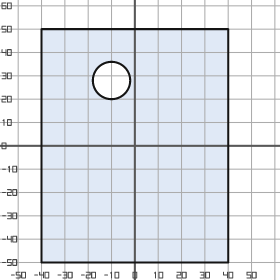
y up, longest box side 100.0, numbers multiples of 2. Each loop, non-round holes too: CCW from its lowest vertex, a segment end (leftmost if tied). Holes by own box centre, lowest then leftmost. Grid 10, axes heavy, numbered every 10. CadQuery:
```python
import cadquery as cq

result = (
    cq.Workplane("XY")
    .moveTo(-40.0, -50.0)
    .lineTo(40.0, -50.0)
    .lineTo(40.0, 50.0)
    .lineTo(-40.0, 50.0)
    .close()
    .moveTo(-10.0, 28.0)
    .circle(8.0)
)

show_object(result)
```